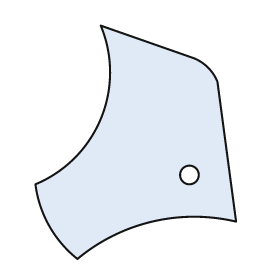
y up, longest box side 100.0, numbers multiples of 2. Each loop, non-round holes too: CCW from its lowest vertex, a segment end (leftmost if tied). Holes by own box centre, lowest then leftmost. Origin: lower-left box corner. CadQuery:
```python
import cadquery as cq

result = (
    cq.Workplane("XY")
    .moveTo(18.0, 0.0)
    .threePointArc((50.0, 16.0), (86.0, 16.0))
    .lineTo(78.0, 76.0)
    .threePointArc((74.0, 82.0), (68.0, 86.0))
    .lineTo(28.0, 100.0)
    .threePointArc((28.0, 60.0), (0.0, 32.0))
    .threePointArc((6.0, 14.0), (18.0, 0.0))
    .close()
    .moveTo(66.0, 36.0)
    .circle(4.0)
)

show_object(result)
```